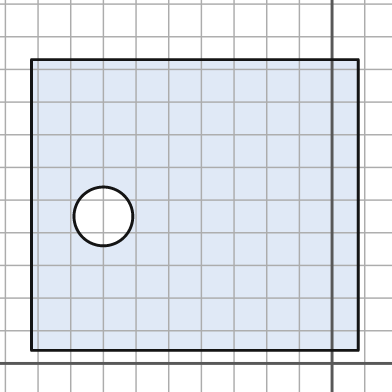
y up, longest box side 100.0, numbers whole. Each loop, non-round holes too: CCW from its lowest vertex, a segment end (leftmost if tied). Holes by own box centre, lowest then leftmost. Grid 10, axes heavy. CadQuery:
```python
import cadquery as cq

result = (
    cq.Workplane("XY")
    .moveTo(-92.0, 4.0)
    .lineTo(8.0, 4.0)
    .lineTo(8.0, 93.0)
    .lineTo(-92.0, 93.0)
    .close()
    .moveTo(-70.0, 45.0)
    .circle(9.0)
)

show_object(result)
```